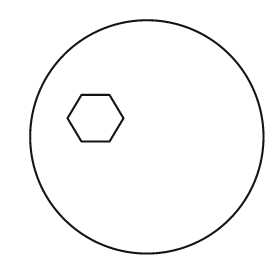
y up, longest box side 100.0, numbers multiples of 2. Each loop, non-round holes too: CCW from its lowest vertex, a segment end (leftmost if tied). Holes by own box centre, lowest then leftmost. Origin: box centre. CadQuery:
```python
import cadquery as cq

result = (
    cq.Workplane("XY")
    .moveTo(0.0, 0.0)
    .circle(50.0)
    .moveTo(-28.0, -2.0)
    .lineTo(-16.0, -2.0)
    .lineTo(-10.0, 8.0)
    .lineTo(-16.0, 18.0)
    .lineTo(-28.0, 18.0)
    .lineTo(-34.0, 8.0)
    .close()
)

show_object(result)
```